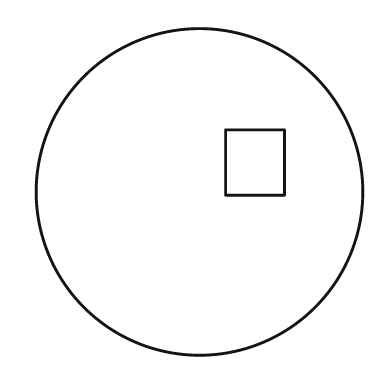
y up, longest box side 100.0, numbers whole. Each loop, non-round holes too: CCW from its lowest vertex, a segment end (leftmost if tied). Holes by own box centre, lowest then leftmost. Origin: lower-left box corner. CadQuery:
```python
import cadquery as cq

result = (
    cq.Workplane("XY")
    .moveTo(50.0, 50.0)
    .circle(50.0)
    .moveTo(58.0, 49.0)
    .lineTo(76.0, 49.0)
    .lineTo(76.0, 69.0)
    .lineTo(58.0, 69.0)
    .close()
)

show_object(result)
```